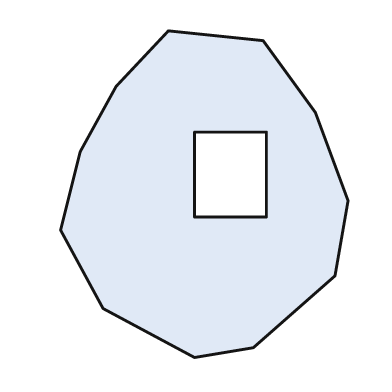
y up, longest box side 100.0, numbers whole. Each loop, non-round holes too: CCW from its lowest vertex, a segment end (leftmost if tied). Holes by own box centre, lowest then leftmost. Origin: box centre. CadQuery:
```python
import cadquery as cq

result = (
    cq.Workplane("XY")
    .moveTo(-3.0, -50.0)
    .lineTo(15.0, -47.0)
    .lineTo(40.0, -25.0)
    .lineTo(44.0, -2.0)
    .lineTo(34.0, 25.0)
    .lineTo(18.0, 47.0)
    .lineTo(-11.0, 50.0)
    .lineTo(-27.0, 33.0)
    .lineTo(-38.0, 13.0)
    .lineTo(-44.0, -11.0)
    .lineTo(-31.0, -35.0)
    .close()
    .moveTo(-3.0, -7.0)
    .lineTo(19.0, -7.0)
    .lineTo(19.0, 19.0)
    .lineTo(-3.0, 19.0)
    .close()
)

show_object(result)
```